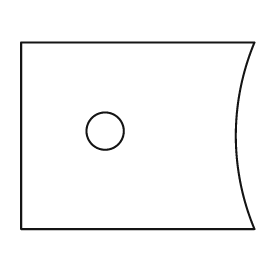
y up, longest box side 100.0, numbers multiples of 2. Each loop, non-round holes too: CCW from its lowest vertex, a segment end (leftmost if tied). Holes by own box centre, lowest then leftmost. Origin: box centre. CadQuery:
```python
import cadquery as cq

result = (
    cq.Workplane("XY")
    .moveTo(-50.0, -40.0)
    .lineTo(50.0, -40.0)
    .threePointArc((42.0, 0.0), (50.0, 40.0))
    .lineTo(-50.0, 40.0)
    .close()
    .moveTo(-14.0, 2.0)
    .circle(8.0)
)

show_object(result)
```